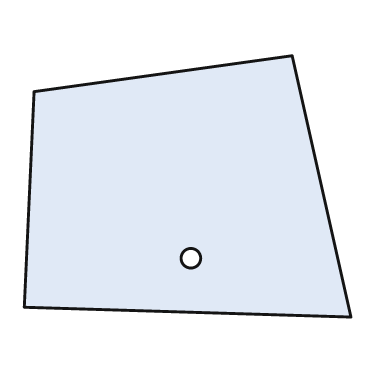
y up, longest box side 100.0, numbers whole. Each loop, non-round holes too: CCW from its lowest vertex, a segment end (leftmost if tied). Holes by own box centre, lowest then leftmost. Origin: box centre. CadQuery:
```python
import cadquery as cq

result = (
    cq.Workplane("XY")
    .moveTo(50.0, -40.0)
    .lineTo(32.0, 40.0)
    .lineTo(-47.0, 29.0)
    .lineTo(-50.0, -37.0)
    .close()
    .moveTo(1.0, -22.0)
    .circle(3.0)
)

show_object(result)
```